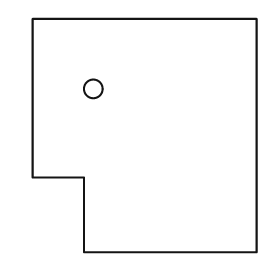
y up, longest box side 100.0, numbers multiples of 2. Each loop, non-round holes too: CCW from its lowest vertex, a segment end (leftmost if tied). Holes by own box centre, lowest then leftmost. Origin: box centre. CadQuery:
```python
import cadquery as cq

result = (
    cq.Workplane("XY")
    .moveTo(-26.0, -50.0)
    .lineTo(48.0, -50.0)
    .lineTo(48.0, 50.0)
    .lineTo(-48.0, 50.0)
    .lineTo(-48.0, -18.0)
    .lineTo(-26.0, -18.0)
    .close()
    .moveTo(-22.0, 20.0)
    .circle(4.0)
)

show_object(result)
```